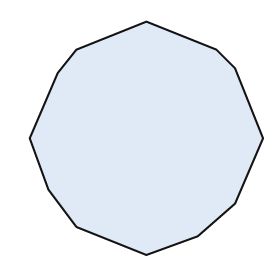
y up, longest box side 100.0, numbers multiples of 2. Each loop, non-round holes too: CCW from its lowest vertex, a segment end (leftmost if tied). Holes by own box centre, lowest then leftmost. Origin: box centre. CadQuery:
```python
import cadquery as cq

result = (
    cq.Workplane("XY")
    .moveTo(0.0, -50.0)
    .lineTo(22.0, -42.0)
    .lineTo(38.0, -28.0)
    .lineTo(50.0, 0.0)
    .lineTo(38.0, 30.0)
    .lineTo(30.0, 38.0)
    .lineTo(0.0, 50.0)
    .lineTo(-30.0, 38.0)
    .lineTo(-38.0, 28.0)
    .lineTo(-50.0, 0.0)
    .lineTo(-42.0, -22.0)
    .lineTo(-30.0, -38.0)
    .close()
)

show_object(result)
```